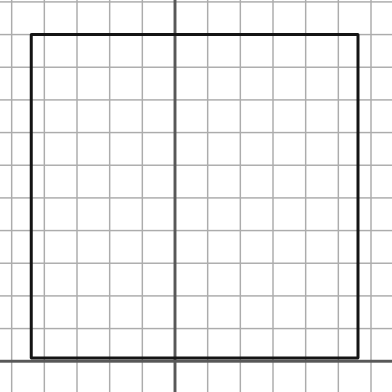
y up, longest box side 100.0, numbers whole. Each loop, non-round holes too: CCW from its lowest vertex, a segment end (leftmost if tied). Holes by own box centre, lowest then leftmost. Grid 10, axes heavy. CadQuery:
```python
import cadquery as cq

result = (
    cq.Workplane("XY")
    .moveTo(-44.0, 1.0)
    .lineTo(56.0, 1.0)
    .lineTo(56.0, 100.0)
    .lineTo(-44.0, 100.0)
    .close()
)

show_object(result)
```